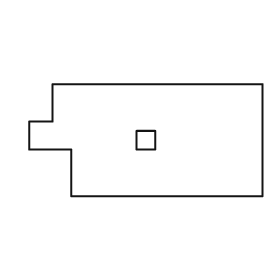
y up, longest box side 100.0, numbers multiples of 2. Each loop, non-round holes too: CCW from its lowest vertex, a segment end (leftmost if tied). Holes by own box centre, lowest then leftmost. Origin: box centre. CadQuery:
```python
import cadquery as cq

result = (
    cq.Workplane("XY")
    .moveTo(-32.0, -24.0)
    .lineTo(50.0, -24.0)
    .lineTo(50.0, 24.0)
    .lineTo(-40.0, 24.0)
    .lineTo(-40.0, 8.0)
    .lineTo(-50.0, 8.0)
    .lineTo(-50.0, -4.0)
    .lineTo(-32.0, -4.0)
    .close()
    .moveTo(-4.0, -4.0)
    .lineTo(4.0, -4.0)
    .lineTo(4.0, 4.0)
    .lineTo(-4.0, 4.0)
    .close()
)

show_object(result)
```